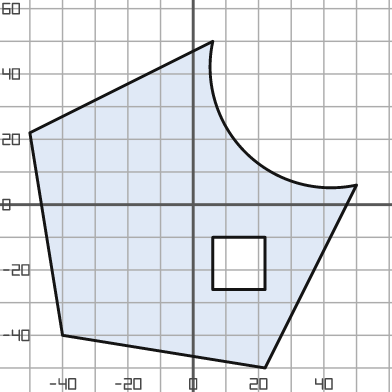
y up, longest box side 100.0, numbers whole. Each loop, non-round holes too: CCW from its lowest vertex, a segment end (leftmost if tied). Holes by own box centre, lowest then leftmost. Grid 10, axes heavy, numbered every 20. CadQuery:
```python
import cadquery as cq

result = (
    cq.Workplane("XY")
    .moveTo(22.0, -50.0)
    .lineTo(50.0, 6.0)
    .threePointArc((16.0, 16.0), (6.0, 50.0))
    .lineTo(-50.0, 22.0)
    .lineTo(-40.0, -40.0)
    .close()
    .moveTo(6.0, -26.0)
    .lineTo(22.0, -26.0)
    .lineTo(22.0, -10.0)
    .lineTo(6.0, -10.0)
    .close()
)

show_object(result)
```